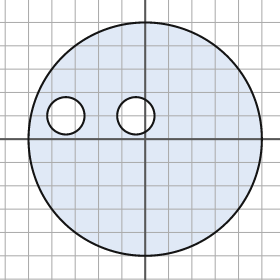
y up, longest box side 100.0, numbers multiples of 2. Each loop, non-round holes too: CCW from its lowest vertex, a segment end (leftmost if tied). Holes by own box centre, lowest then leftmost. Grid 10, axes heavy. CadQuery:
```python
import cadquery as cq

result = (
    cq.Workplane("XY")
    .moveTo(0.0, 0.0)
    .circle(50.0)
    .moveTo(-34.0, 10.0)
    .circle(8.0)
    .moveTo(-4.0, 10.0)
    .circle(8.0)
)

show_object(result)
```